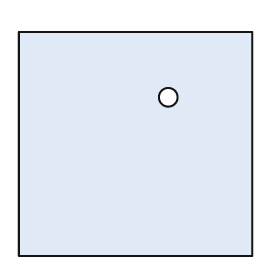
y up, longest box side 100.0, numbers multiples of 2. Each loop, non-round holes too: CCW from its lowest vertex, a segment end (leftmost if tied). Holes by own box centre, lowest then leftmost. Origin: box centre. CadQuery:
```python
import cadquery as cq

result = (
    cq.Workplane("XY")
    .moveTo(-50.0, -48.0)
    .lineTo(50.0, -48.0)
    .lineTo(50.0, 48.0)
    .lineTo(-50.0, 48.0)
    .close()
    .moveTo(14.0, 20.0)
    .circle(4.0)
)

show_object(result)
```